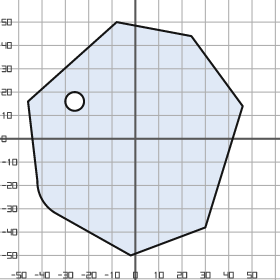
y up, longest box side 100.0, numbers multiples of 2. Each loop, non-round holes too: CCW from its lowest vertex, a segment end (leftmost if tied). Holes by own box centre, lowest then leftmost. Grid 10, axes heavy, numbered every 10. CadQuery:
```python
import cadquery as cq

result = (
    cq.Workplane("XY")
    .moveTo(-2.0, -50.0)
    .lineTo(30.0, -38.0)
    .lineTo(46.0, 14.0)
    .lineTo(24.0, 44.0)
    .lineTo(-8.0, 50.0)
    .lineTo(-46.0, 16.0)
    .lineTo(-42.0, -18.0)
    .threePointArc((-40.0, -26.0), (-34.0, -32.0))
    .close()
    .moveTo(-26.0, 16.0)
    .circle(4.0)
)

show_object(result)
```